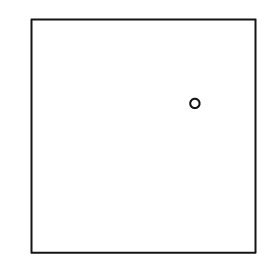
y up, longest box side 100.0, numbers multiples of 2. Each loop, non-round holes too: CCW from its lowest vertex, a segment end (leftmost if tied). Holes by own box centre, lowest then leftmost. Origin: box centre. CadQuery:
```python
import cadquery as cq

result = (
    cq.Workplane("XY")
    .moveTo(-48.0, -50.0)
    .lineTo(48.0, -50.0)
    .lineTo(48.0, 50.0)
    .lineTo(-48.0, 50.0)
    .close()
    .moveTo(22.0, 14.0)
    .circle(2.0)
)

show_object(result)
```